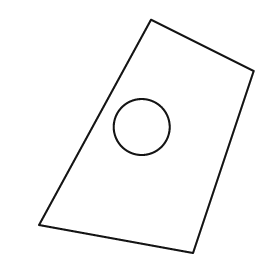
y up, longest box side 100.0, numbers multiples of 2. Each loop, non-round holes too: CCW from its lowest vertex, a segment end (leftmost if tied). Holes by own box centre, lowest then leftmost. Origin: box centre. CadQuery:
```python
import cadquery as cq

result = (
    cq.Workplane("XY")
    .moveTo(20.0, -50.0)
    .lineTo(46.0, 28.0)
    .lineTo(2.0, 50.0)
    .lineTo(-46.0, -38.0)
    .close()
    .moveTo(-2.0, 4.0)
    .circle(12.0)
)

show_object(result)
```